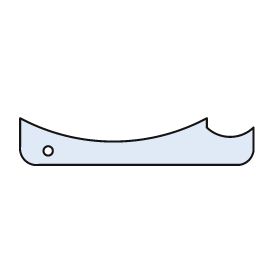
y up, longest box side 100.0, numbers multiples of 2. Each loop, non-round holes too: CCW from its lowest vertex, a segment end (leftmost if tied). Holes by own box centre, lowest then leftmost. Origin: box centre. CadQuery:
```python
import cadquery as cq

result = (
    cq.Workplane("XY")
    .moveTo(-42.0, -10.0)
    .lineTo(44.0, -10.0)
    .threePointArc((48.0, -8.0), (50.0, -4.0))
    .lineTo(50.0, 6.0)
    .threePointArc((40.0, 2.0), (30.0, 6.0))
    .lineTo(30.0, 10.0)
    .threePointArc((-10.0, 0.0), (-50.0, 10.0))
    .lineTo(-50.0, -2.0)
    .threePointArc((-48.0, -8.0), (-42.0, -10.0))
    .close()
    .moveTo(-38.0, -4.0)
    .circle(2.0)
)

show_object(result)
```